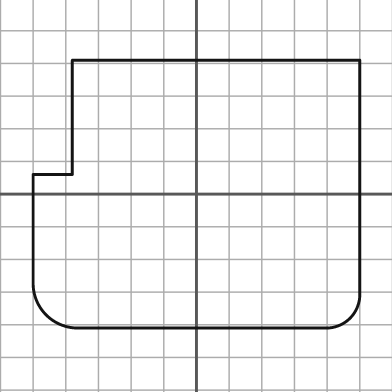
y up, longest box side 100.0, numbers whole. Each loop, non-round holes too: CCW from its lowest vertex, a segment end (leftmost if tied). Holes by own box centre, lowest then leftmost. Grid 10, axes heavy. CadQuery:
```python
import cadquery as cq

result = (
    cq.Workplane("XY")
    .moveTo(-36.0, -41.0)
    .lineTo(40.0, -41.0)
    .threePointArc((47.0, -38.0), (50.0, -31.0))
    .lineTo(50.0, 41.0)
    .lineTo(-38.0, 41.0)
    .lineTo(-38.0, 6.0)
    .lineTo(-50.0, 6.0)
    .lineTo(-50.0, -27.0)
    .threePointArc((-46.0, -37.0), (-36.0, -41.0))
    .close()
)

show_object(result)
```